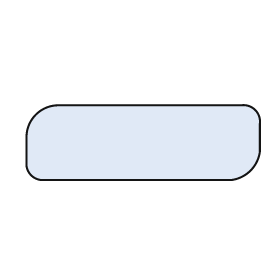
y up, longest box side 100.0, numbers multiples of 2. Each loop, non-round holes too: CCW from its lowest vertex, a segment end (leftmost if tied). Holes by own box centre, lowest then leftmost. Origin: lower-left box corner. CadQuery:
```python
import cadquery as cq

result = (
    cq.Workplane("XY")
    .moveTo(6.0, 0.0)
    .lineTo(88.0, 0.0)
    .threePointArc((96.0, 4.0), (100.0, 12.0))
    .lineTo(100.0, 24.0)
    .threePointArc((98.0, 30.0), (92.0, 32.0))
    .lineTo(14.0, 32.0)
    .threePointArc((4.0, 28.0), (0.0, 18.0))
    .lineTo(0.0, 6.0)
    .threePointArc((2.0, 2.0), (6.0, 0.0))
    .close()
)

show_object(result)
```